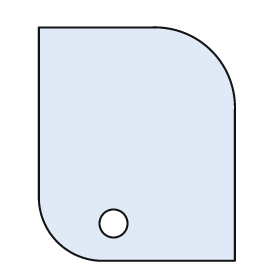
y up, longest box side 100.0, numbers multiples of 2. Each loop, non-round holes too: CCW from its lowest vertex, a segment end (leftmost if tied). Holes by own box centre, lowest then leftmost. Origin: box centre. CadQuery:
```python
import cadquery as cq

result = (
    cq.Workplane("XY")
    .moveTo(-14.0, -50.0)
    .lineTo(42.0, -50.0)
    .lineTo(42.0, 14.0)
    .threePointArc((32.0, 40.0), (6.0, 50.0))
    .lineTo(-42.0, 50.0)
    .lineTo(-42.0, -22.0)
    .threePointArc((-34.0, -42.0), (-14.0, -50.0))
    .close()
    .moveTo(-10.0, -34.0)
    .circle(6.0)
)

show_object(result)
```